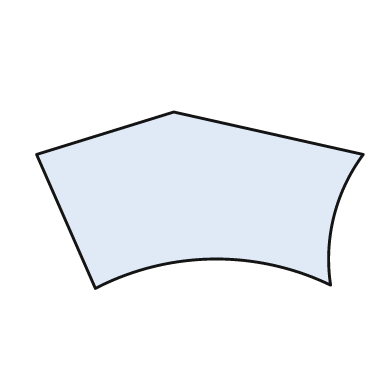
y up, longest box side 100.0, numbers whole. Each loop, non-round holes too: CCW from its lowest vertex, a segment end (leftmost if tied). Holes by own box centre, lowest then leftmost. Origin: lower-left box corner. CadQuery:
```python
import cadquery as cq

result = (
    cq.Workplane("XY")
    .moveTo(18.0, 0.0)
    .threePointArc((54.0, 9.0), (90.0, 1.0))
    .threePointArc((91.0, 22.0), (100.0, 41.0))
    .lineTo(42.0, 54.0)
    .lineTo(0.0, 41.0)
    .close()
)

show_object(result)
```